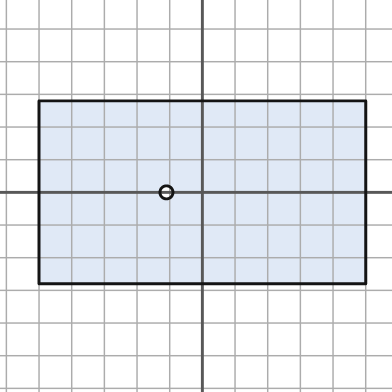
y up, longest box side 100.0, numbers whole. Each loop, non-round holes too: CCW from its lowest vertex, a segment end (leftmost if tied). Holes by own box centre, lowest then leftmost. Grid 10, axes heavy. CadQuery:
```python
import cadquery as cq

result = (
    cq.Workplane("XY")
    .moveTo(-50.0, -28.0)
    .lineTo(50.0, -28.0)
    .lineTo(50.0, 28.0)
    .lineTo(-50.0, 28.0)
    .close()
    .moveTo(-11.0, 0.0)
    .circle(2.0)
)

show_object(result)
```